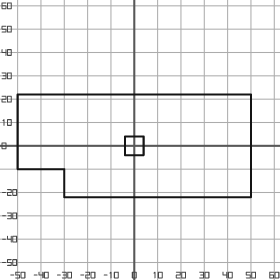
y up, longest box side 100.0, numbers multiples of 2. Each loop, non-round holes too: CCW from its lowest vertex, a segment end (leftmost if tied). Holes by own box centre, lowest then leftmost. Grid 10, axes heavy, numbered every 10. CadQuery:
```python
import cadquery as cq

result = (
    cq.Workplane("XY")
    .moveTo(-30.0, -22.0)
    .lineTo(50.0, -22.0)
    .lineTo(50.0, 22.0)
    .lineTo(-50.0, 22.0)
    .lineTo(-50.0, -10.0)
    .lineTo(-30.0, -10.0)
    .close()
    .moveTo(-4.0, -4.0)
    .lineTo(4.0, -4.0)
    .lineTo(4.0, 4.0)
    .lineTo(-4.0, 4.0)
    .close()
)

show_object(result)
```